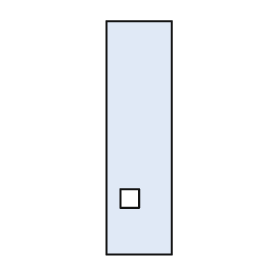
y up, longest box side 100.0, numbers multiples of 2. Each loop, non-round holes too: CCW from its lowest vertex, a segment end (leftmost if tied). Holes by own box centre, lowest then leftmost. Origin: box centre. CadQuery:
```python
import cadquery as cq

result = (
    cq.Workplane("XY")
    .moveTo(-14.0, -50.0)
    .lineTo(14.0, -50.0)
    .lineTo(14.0, 50.0)
    .lineTo(-14.0, 50.0)
    .close()
    .moveTo(-8.0, -30.0)
    .lineTo(0.0, -30.0)
    .lineTo(0.0, -22.0)
    .lineTo(-8.0, -22.0)
    .close()
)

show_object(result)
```